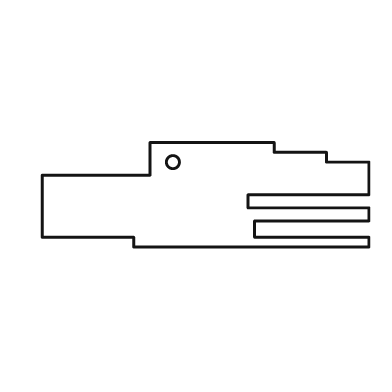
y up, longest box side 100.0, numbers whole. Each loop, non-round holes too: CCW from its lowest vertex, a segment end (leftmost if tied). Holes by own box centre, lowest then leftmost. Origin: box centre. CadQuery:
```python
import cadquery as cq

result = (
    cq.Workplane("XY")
    .moveTo(-22.0, -16.0)
    .lineTo(50.0, -16.0)
    .lineTo(50.0, -13.0)
    .lineTo(15.0, -13.0)
    .lineTo(15.0, -8.0)
    .lineTo(50.0, -8.0)
    .lineTo(50.0, -4.0)
    .lineTo(13.0, -4.0)
    .lineTo(13.0, 0.0)
    .lineTo(50.0, 0.0)
    .lineTo(50.0, 10.0)
    .lineTo(37.0, 10.0)
    .lineTo(37.0, 13.0)
    .lineTo(21.0, 13.0)
    .lineTo(21.0, 16.0)
    .lineTo(-17.0, 16.0)
    .lineTo(-17.0, 6.0)
    .lineTo(-50.0, 6.0)
    .lineTo(-50.0, -13.0)
    .lineTo(-22.0, -13.0)
    .close()
    .moveTo(-10.0, 10.0)
    .circle(2.0)
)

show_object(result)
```